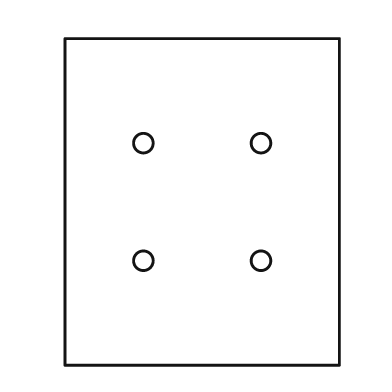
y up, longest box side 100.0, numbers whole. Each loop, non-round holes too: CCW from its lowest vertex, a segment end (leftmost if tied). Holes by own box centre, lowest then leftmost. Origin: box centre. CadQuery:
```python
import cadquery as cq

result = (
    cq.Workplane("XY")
    .moveTo(-42.0, -50.0)
    .lineTo(42.0, -50.0)
    .lineTo(42.0, 50.0)
    .lineTo(-42.0, 50.0)
    .close()
    .moveTo(-18.0, -18.0)
    .circle(3.0)
    .moveTo(18.0, -18.0)
    .circle(3.0)
    .moveTo(-18.0, 18.0)
    .circle(3.0)
    .moveTo(18.0, 18.0)
    .circle(3.0)
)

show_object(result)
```